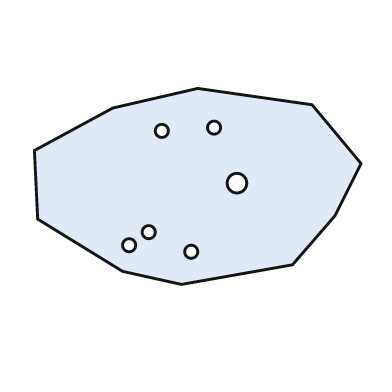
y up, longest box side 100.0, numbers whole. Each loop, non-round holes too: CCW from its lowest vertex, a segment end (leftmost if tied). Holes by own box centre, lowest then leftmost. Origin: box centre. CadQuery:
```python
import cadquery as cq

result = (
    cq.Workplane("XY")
    .moveTo(-5.0, -30.0)
    .lineTo(29.0, -24.0)
    .lineTo(42.0, -9.0)
    .lineTo(50.0, 7.0)
    .lineTo(35.0, 25.0)
    .lineTo(0.0, 30.0)
    .lineTo(-26.0, 24.0)
    .lineTo(-50.0, 11.0)
    .lineTo(-49.0, -10.0)
    .lineTo(-23.0, -26.0)
    .close()
    .moveTo(-2.0, -20.0)
    .circle(2.0)
    .moveTo(-21.0, -18.0)
    .circle(2.0)
    .moveTo(-15.0, -14.0)
    .circle(2.0)
    .moveTo(12.0, 1.0)
    .circle(3.0)
    .moveTo(-11.0, 17.0)
    .circle(2.0)
    .moveTo(5.0, 18.0)
    .circle(2.0)
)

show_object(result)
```